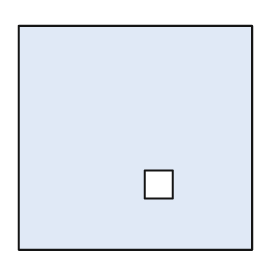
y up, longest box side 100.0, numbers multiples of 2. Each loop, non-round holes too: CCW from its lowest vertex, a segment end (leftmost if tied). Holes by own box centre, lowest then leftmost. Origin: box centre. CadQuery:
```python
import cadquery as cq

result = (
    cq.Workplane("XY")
    .moveTo(-50.0, -48.0)
    .lineTo(50.0, -48.0)
    .lineTo(50.0, 48.0)
    .lineTo(-50.0, 48.0)
    .close()
    .moveTo(4.0, -26.0)
    .lineTo(16.0, -26.0)
    .lineTo(16.0, -14.0)
    .lineTo(4.0, -14.0)
    .close()
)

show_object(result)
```